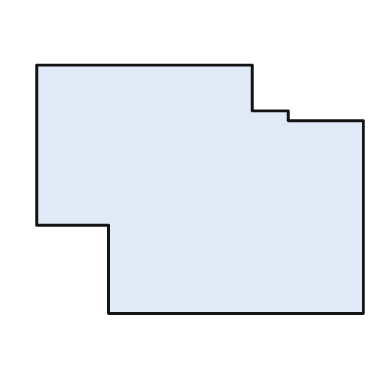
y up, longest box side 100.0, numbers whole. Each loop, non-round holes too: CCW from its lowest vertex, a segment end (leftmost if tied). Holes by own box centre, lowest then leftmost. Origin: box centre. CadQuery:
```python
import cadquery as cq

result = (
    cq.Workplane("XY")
    .moveTo(-28.0, -38.0)
    .lineTo(50.0, -38.0)
    .lineTo(50.0, 21.0)
    .lineTo(27.0, 21.0)
    .lineTo(27.0, 24.0)
    .lineTo(16.0, 24.0)
    .lineTo(16.0, 38.0)
    .lineTo(-50.0, 38.0)
    .lineTo(-50.0, -11.0)
    .lineTo(-28.0, -11.0)
    .close()
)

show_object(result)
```